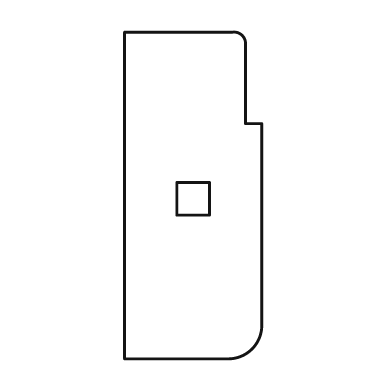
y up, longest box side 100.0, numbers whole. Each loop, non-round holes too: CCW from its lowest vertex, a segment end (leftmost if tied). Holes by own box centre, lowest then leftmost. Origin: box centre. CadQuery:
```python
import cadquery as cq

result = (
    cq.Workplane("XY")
    .moveTo(-21.0, -50.0)
    .lineTo(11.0, -50.0)
    .threePointArc((18.0, -47.0), (21.0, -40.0))
    .lineTo(21.0, 22.0)
    .lineTo(16.0, 22.0)
    .lineTo(16.0, 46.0)
    .threePointArc((15.0, 49.0), (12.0, 50.0))
    .lineTo(-21.0, 50.0)
    .close()
    .moveTo(-5.0, -6.0)
    .lineTo(5.0, -6.0)
    .lineTo(5.0, 4.0)
    .lineTo(-5.0, 4.0)
    .close()
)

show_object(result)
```